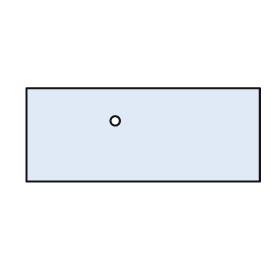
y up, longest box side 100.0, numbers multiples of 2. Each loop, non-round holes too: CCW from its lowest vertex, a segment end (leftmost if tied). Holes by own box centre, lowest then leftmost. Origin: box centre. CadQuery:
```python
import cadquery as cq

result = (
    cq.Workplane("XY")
    .moveTo(-50.0, -20.0)
    .lineTo(50.0, -20.0)
    .lineTo(50.0, 20.0)
    .lineTo(-50.0, 20.0)
    .close()
    .moveTo(-12.0, 6.0)
    .circle(2.0)
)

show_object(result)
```